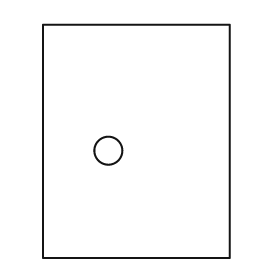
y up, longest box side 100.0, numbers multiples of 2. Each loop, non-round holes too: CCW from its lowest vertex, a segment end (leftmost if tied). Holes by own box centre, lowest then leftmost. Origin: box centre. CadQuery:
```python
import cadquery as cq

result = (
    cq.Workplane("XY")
    .moveTo(-40.0, -50.0)
    .lineTo(40.0, -50.0)
    .lineTo(40.0, 50.0)
    .lineTo(-40.0, 50.0)
    .close()
    .moveTo(-12.0, -4.0)
    .circle(6.0)
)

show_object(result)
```